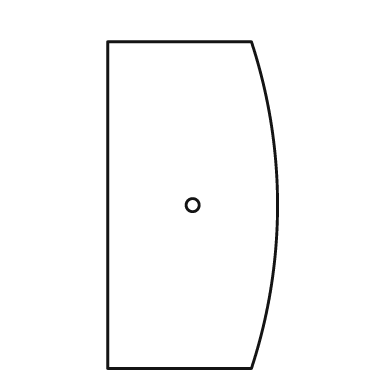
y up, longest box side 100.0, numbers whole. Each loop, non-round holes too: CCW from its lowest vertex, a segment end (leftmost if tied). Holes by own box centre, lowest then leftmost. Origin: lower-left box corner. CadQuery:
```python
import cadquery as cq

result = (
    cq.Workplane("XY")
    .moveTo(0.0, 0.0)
    .lineTo(44.0, 0.0)
    .threePointArc((52.0, 50.0), (44.0, 100.0))
    .lineTo(0.0, 100.0)
    .close()
    .moveTo(26.0, 50.0)
    .circle(2.0)
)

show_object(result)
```